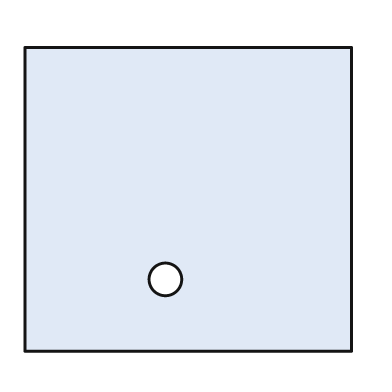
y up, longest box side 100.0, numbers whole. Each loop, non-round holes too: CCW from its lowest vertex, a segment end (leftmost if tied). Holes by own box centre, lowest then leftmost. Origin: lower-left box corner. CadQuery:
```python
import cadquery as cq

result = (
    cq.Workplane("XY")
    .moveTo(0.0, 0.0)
    .lineTo(100.0, 0.0)
    .lineTo(100.0, 93.0)
    .lineTo(0.0, 93.0)
    .close()
    .moveTo(43.0, 22.0)
    .circle(5.0)
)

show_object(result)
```